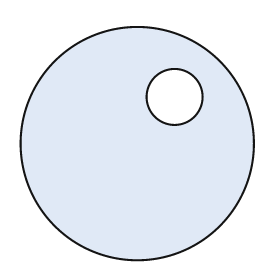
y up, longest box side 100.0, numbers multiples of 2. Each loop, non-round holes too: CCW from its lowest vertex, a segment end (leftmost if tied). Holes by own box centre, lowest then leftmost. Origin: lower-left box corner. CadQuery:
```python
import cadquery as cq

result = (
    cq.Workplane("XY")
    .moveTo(50.0, 50.0)
    .circle(50.0)
    .moveTo(66.0, 70.0)
    .circle(12.0)
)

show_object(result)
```